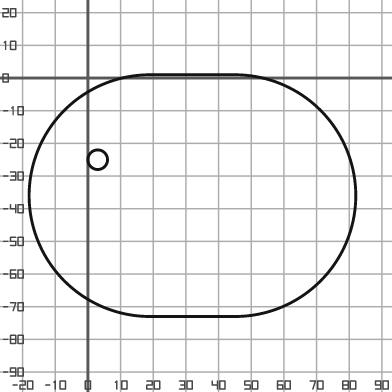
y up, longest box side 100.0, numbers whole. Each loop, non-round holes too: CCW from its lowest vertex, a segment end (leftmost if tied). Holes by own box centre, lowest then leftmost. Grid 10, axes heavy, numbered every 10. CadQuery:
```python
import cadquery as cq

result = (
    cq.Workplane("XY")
    .moveTo(19.0, -73.0)
    .lineTo(45.0, -73.0)
    .threePointArc((82.0, -36.0), (45.0, 1.0))
    .lineTo(19.0, 1.0)
    .threePointArc((-18.0, -36.0), (19.0, -73.0))
    .close()
    .moveTo(3.0, -25.0)
    .circle(3.0)
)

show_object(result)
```